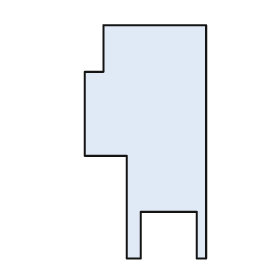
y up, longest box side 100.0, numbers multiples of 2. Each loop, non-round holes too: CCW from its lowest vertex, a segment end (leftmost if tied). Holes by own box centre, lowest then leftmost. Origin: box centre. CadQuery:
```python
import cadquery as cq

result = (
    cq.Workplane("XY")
    .moveTo(-8.0, -50.0)
    .lineTo(-2.0, -50.0)
    .lineTo(-2.0, -30.0)
    .lineTo(22.0, -30.0)
    .lineTo(22.0, -50.0)
    .lineTo(26.0, -50.0)
    .lineTo(26.0, 50.0)
    .lineTo(-18.0, 50.0)
    .lineTo(-18.0, 30.0)
    .lineTo(-26.0, 30.0)
    .lineTo(-26.0, -6.0)
    .lineTo(-8.0, -6.0)
    .close()
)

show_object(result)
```